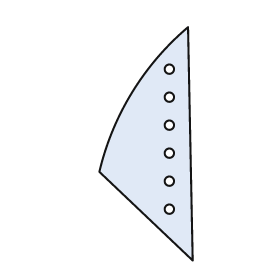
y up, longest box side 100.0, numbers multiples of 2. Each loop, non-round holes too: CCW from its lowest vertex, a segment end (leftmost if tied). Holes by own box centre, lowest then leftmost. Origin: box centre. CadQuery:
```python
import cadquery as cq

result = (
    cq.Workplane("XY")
    .moveTo(20.0, -50.0)
    .lineTo(18.0, 50.0)
    .threePointArc((-6.0, 22.0), (-20.0, -12.0))
    .close()
    .moveTo(10.0, -28.0)
    .circle(2.0)
    .moveTo(10.0, -16.0)
    .circle(2.0)
    .moveTo(10.0, -4.0)
    .circle(2.0)
    .moveTo(10.0, 8.0)
    .circle(2.0)
    .moveTo(10.0, 20.0)
    .circle(2.0)
    .moveTo(10.0, 32.0)
    .circle(2.0)
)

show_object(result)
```